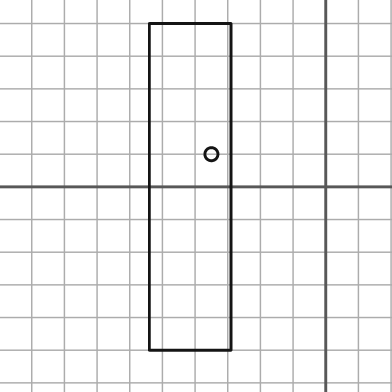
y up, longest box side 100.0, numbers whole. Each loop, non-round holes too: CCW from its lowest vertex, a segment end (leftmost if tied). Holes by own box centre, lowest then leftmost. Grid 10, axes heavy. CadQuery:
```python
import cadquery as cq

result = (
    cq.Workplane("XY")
    .moveTo(-54.0, -50.0)
    .lineTo(-29.0, -50.0)
    .lineTo(-29.0, 50.0)
    .lineTo(-54.0, 50.0)
    .close()
    .moveTo(-35.0, 10.0)
    .circle(2.0)
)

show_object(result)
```